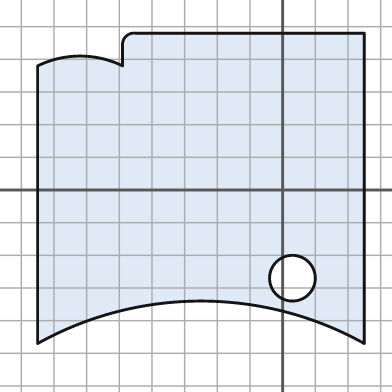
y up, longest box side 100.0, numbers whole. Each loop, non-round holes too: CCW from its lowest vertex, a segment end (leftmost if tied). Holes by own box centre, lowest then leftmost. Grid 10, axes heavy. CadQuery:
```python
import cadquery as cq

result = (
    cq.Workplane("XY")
    .moveTo(-75.0, -47.0)
    .threePointArc((-25.0, -34.0), (25.0, -47.0))
    .lineTo(25.0, 48.0)
    .lineTo(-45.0, 48.0)
    .threePointArc((-48.0, 47.0), (-49.0, 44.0))
    .lineTo(-49.0, 38.0)
    .threePointArc((-62.0, 41.0), (-75.0, 38.0))
    .close()
    .moveTo(3.0, -27.0)
    .circle(7.0)
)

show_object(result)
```